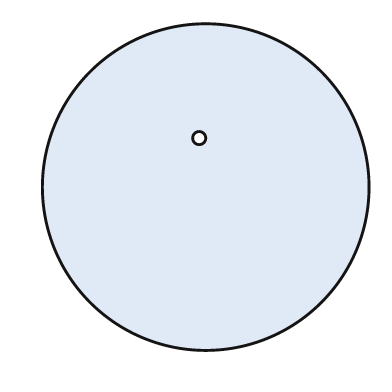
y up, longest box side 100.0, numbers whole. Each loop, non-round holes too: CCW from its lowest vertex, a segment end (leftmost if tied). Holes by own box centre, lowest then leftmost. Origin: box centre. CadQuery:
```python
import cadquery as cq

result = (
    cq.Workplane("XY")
    .moveTo(0.0, 0.0)
    .circle(50.0)
    .moveTo(-2.0, 15.0)
    .circle(2.0)
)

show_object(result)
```